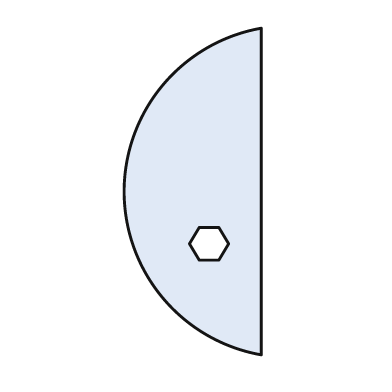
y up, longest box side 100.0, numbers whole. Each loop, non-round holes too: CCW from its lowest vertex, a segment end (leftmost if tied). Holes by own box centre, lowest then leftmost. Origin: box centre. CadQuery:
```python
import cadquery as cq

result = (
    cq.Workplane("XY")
    .moveTo(21.0, -50.0)
    .lineTo(21.0, 50.0)
    .threePointArc((-21.0, 0.0), (21.0, -50.0))
    .close()
    .moveTo(2.0, -21.0)
    .lineTo(8.0, -21.0)
    .lineTo(11.0, -16.0)
    .lineTo(8.0, -11.0)
    .lineTo(2.0, -11.0)
    .lineTo(-1.0, -16.0)
    .close()
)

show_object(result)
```